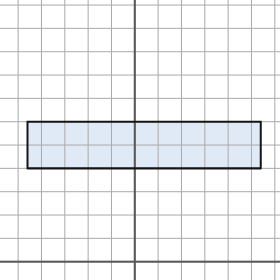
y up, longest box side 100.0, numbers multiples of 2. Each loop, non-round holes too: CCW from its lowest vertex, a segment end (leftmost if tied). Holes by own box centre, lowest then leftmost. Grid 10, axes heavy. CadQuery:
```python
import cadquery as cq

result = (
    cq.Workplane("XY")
    .moveTo(-46.0, 40.0)
    .lineTo(54.0, 40.0)
    .lineTo(54.0, 60.0)
    .lineTo(-46.0, 60.0)
    .close()
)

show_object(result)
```